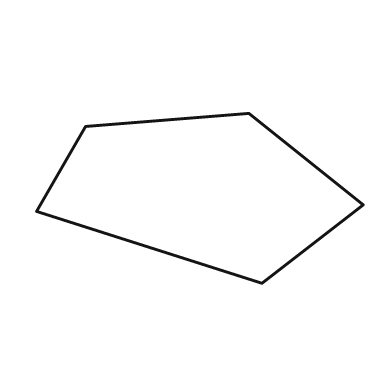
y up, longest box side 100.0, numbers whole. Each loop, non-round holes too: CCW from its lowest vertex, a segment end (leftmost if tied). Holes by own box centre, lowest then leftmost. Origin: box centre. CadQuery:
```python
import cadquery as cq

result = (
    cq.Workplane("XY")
    .moveTo(19.0, -26.0)
    .lineTo(50.0, -2.0)
    .lineTo(15.0, 26.0)
    .lineTo(-35.0, 22.0)
    .lineTo(-50.0, -4.0)
    .close()
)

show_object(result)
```